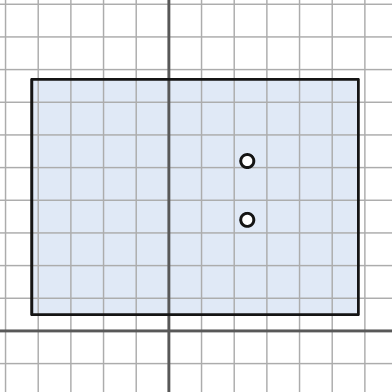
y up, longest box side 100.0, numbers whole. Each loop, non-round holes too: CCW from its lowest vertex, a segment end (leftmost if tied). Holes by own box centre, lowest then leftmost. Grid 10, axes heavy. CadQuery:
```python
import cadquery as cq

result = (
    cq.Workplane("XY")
    .moveTo(-42.0, 5.0)
    .lineTo(58.0, 5.0)
    .lineTo(58.0, 77.0)
    .lineTo(-42.0, 77.0)
    .close()
    .moveTo(24.0, 34.0)
    .circle(2.0)
    .moveTo(24.0, 52.0)
    .circle(2.0)
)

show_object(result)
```